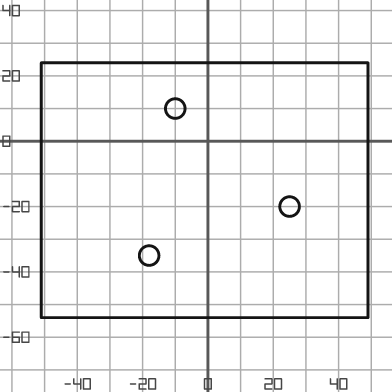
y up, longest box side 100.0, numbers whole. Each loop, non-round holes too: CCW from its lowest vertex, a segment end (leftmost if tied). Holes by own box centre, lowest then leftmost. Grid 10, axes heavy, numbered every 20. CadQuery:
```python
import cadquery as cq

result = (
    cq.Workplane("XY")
    .moveTo(-51.0, -54.0)
    .lineTo(49.0, -54.0)
    .lineTo(49.0, 24.0)
    .lineTo(-51.0, 24.0)
    .close()
    .moveTo(-18.0, -35.0)
    .circle(3.0)
    .moveTo(25.0, -20.0)
    .circle(3.0)
    .moveTo(-10.0, 10.0)
    .circle(3.0)
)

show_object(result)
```